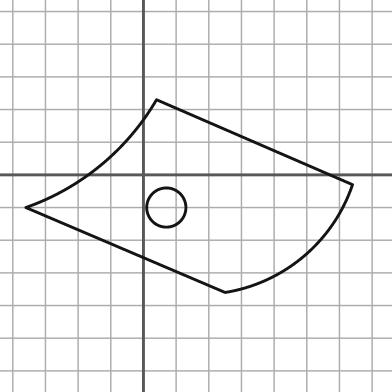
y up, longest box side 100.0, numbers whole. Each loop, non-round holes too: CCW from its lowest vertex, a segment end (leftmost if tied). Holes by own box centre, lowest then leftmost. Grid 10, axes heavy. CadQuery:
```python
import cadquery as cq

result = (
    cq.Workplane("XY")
    .moveTo(25.0, -36.0)
    .threePointArc((49.0, -25.0), (64.0, -3.0))
    .lineTo(4.0, 23.0)
    .threePointArc((-13.0, 3.0), (-36.0, -10.0))
    .close()
    .moveTo(7.0, -10.0)
    .circle(6.0)
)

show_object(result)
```